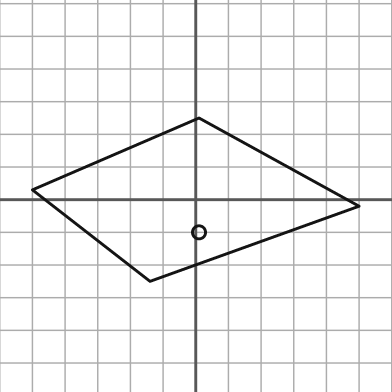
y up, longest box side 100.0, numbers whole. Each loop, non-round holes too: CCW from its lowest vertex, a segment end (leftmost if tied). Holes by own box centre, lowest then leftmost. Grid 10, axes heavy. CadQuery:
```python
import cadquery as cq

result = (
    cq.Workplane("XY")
    .moveTo(-14.0, -25.0)
    .lineTo(50.0, -2.0)
    .lineTo(1.0, 25.0)
    .lineTo(-50.0, 3.0)
    .close()
    .moveTo(1.0, -10.0)
    .circle(2.0)
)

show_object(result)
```